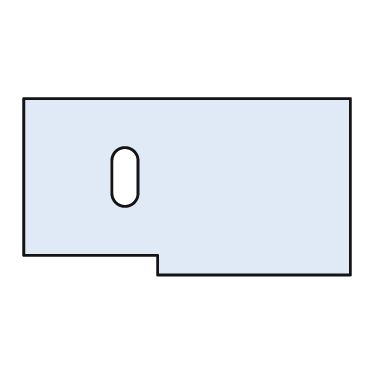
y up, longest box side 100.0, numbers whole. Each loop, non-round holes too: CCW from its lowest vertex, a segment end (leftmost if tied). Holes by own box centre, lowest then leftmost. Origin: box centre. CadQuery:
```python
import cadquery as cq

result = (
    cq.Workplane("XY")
    .moveTo(-9.0, -27.0)
    .lineTo(50.0, -27.0)
    .lineTo(50.0, 27.0)
    .lineTo(-50.0, 27.0)
    .lineTo(-50.0, -21.0)
    .lineTo(-9.0, -21.0)
    .close()
    .moveTo(-23.0, -2.0)
    .threePointArc((-19.0, -6.0), (-15.0, -2.0))
    .lineTo(-15.0, 8.0)
    .threePointArc((-19.0, 12.0), (-23.0, 8.0))
    .close()
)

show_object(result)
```